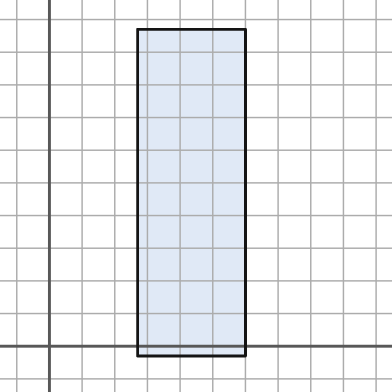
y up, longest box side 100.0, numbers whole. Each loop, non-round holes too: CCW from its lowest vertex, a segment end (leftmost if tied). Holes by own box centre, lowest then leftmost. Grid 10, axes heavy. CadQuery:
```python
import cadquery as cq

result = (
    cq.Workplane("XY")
    .moveTo(27.0, -3.0)
    .lineTo(60.0, -3.0)
    .lineTo(60.0, 97.0)
    .lineTo(27.0, 97.0)
    .close()
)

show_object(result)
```